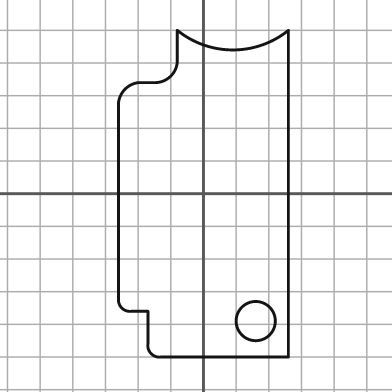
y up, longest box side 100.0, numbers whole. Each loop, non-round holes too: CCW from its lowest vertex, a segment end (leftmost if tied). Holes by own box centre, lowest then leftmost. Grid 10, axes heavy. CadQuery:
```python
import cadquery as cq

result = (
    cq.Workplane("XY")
    .moveTo(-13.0, -50.0)
    .lineTo(26.0, -50.0)
    .lineTo(26.0, 50.0)
    .threePointArc((9.0, 44.0), (-8.0, 50.0))
    .lineTo(-8.0, 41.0)
    .threePointArc((-10.0, 36.0), (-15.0, 34.0))
    .lineTo(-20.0, 34.0)
    .threePointArc((-24.0, 32.0), (-26.0, 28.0))
    .lineTo(-26.0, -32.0)
    .threePointArc((-25.0, -35.0), (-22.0, -36.0))
    .lineTo(-17.0, -36.0)
    .lineTo(-17.0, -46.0)
    .threePointArc((-16.0, -49.0), (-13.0, -50.0))
    .close()
    .moveTo(16.0, -39.0)
    .circle(6.0)
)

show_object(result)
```